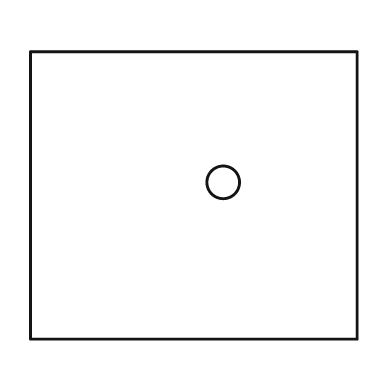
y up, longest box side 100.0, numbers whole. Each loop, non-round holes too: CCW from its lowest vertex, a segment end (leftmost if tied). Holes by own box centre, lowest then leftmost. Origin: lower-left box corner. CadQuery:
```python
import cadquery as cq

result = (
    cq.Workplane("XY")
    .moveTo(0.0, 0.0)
    .lineTo(100.0, 0.0)
    .lineTo(100.0, 88.0)
    .lineTo(0.0, 88.0)
    .close()
    .moveTo(59.0, 48.0)
    .circle(5.0)
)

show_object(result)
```